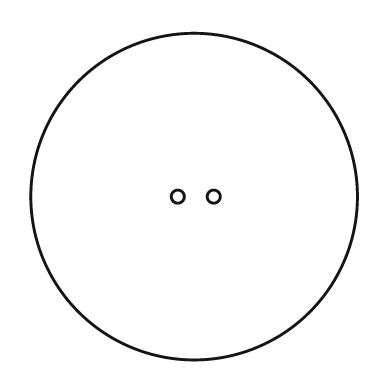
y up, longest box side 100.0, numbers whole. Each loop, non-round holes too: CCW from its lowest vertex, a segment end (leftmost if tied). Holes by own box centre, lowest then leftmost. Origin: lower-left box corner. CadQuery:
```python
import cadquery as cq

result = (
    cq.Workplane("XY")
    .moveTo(50.0, 50.0)
    .circle(50.0)
    .moveTo(45.0, 50.0)
    .circle(2.0)
    .moveTo(56.0, 50.0)
    .circle(2.0)
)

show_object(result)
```